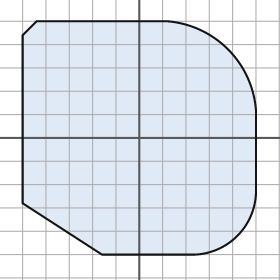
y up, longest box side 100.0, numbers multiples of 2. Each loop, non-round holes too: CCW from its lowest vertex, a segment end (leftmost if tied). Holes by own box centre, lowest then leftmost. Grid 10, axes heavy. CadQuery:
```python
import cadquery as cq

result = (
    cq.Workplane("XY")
    .moveTo(-16.0, -50.0)
    .lineTo(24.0, -50.0)
    .threePointArc((42.0, -42.0), (50.0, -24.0))
    .lineTo(50.0, 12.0)
    .threePointArc((38.0, 38.0), (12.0, 50.0))
    .lineTo(-44.0, 50.0)
    .lineTo(-50.0, 44.0)
    .lineTo(-50.0, -28.0)
    .close()
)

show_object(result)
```